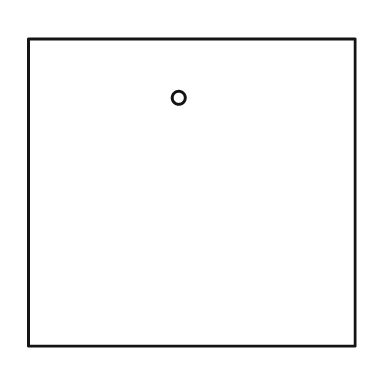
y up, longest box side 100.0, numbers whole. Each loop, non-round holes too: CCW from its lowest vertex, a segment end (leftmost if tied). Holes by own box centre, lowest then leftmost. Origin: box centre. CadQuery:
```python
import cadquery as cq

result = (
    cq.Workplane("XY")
    .moveTo(-50.0, -47.0)
    .lineTo(50.0, -47.0)
    .lineTo(50.0, 47.0)
    .lineTo(-50.0, 47.0)
    .close()
    .moveTo(-4.0, 29.0)
    .circle(2.0)
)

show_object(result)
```